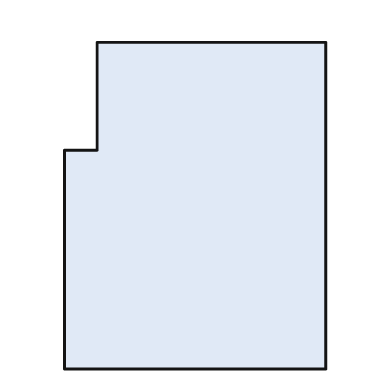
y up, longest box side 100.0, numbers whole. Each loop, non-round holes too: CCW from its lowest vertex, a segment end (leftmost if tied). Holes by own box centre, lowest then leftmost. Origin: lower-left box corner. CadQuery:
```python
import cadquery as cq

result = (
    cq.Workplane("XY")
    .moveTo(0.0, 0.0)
    .lineTo(80.0, 0.0)
    .lineTo(80.0, 100.0)
    .lineTo(10.0, 100.0)
    .lineTo(10.0, 67.0)
    .lineTo(0.0, 67.0)
    .close()
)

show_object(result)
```